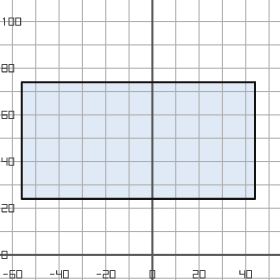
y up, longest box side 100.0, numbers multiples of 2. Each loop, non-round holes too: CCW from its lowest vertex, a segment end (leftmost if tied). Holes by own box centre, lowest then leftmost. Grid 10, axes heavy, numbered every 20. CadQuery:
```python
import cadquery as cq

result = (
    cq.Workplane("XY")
    .moveTo(-56.0, 24.0)
    .lineTo(44.0, 24.0)
    .lineTo(44.0, 74.0)
    .lineTo(-56.0, 74.0)
    .close()
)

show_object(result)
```